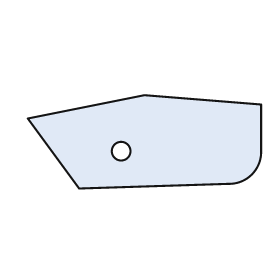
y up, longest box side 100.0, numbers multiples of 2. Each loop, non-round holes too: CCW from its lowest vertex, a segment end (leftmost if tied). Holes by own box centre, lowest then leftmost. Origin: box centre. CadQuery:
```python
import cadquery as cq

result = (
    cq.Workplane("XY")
    .moveTo(-28.0, -20.0)
    .lineTo(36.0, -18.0)
    .threePointArc((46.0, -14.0), (50.0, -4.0))
    .lineTo(50.0, 16.0)
    .lineTo(0.0, 20.0)
    .lineTo(-50.0, 10.0)
    .close()
    .moveTo(-10.0, -4.0)
    .circle(4.0)
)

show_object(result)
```